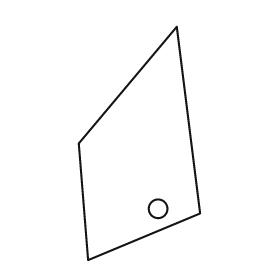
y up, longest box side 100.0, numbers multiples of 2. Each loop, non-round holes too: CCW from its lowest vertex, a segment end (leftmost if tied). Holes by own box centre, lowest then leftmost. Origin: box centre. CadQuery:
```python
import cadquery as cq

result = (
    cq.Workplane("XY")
    .moveTo(-22.0, -50.0)
    .lineTo(26.0, -30.0)
    .lineTo(16.0, 50.0)
    .lineTo(-26.0, 0.0)
    .close()
    .moveTo(8.0, -28.0)
    .circle(4.0)
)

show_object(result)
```